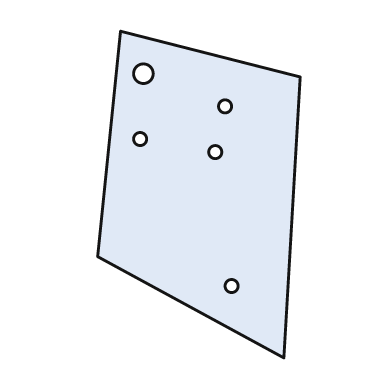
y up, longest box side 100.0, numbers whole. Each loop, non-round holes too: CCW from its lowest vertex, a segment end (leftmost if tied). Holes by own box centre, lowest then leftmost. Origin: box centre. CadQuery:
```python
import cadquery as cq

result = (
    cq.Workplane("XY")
    .moveTo(26.0, -50.0)
    .lineTo(31.0, 36.0)
    .lineTo(-24.0, 50.0)
    .lineTo(-31.0, -19.0)
    .close()
    .moveTo(10.0, -28.0)
    .circle(2.0)
    .moveTo(5.0, 13.0)
    .circle(2.0)
    .moveTo(-18.0, 17.0)
    .circle(2.0)
    .moveTo(8.0, 27.0)
    .circle(2.0)
    .moveTo(-17.0, 37.0)
    .circle(3.0)
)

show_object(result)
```